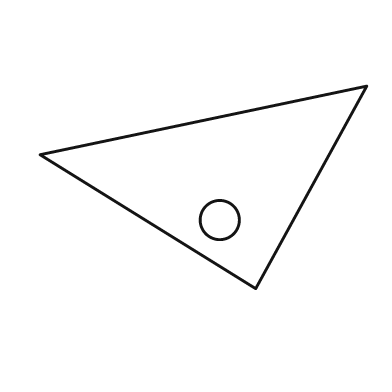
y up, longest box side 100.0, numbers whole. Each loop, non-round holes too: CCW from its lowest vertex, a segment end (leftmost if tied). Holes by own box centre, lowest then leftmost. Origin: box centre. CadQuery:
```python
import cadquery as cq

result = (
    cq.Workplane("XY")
    .moveTo(16.0, -31.0)
    .lineTo(50.0, 31.0)
    .lineTo(-50.0, 10.0)
    .close()
    .moveTo(5.0, -10.0)
    .circle(6.0)
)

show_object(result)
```